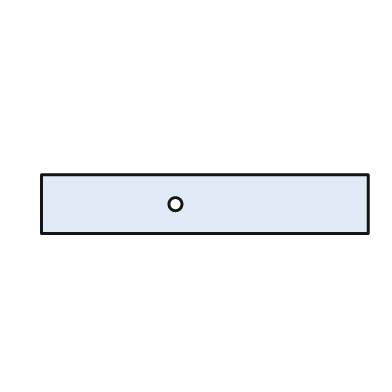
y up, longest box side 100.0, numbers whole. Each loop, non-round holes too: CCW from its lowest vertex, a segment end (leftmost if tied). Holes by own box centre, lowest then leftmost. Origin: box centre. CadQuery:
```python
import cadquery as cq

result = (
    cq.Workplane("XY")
    .moveTo(-50.0, -9.0)
    .lineTo(50.0, -9.0)
    .lineTo(50.0, 9.0)
    .lineTo(-50.0, 9.0)
    .close()
    .moveTo(-9.0, 0.0)
    .circle(2.0)
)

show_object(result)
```